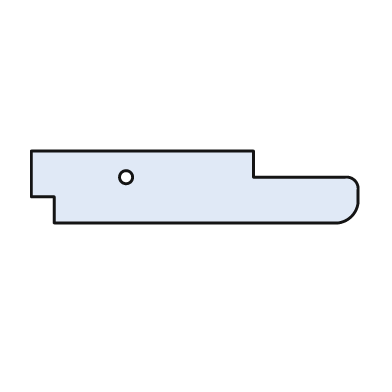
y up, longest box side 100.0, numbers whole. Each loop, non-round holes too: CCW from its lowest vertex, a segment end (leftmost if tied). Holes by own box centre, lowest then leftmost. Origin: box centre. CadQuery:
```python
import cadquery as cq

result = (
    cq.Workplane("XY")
    .moveTo(-43.0, -11.0)
    .lineTo(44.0, -11.0)
    .threePointArc((48.0, -9.0), (50.0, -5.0))
    .lineTo(50.0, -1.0)
    .threePointArc((49.0, 2.0), (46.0, 3.0))
    .lineTo(18.0, 3.0)
    .lineTo(18.0, 11.0)
    .lineTo(-50.0, 11.0)
    .lineTo(-50.0, -3.0)
    .lineTo(-43.0, -3.0)
    .close()
    .moveTo(-21.0, 3.0)
    .circle(2.0)
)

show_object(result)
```